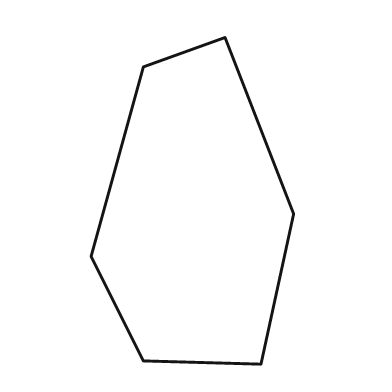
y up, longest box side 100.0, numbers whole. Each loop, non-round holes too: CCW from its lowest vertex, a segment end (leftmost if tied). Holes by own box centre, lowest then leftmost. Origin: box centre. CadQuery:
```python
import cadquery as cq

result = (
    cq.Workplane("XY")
    .moveTo(21.0, -50.0)
    .lineTo(31.0, -4.0)
    .lineTo(10.0, 50.0)
    .lineTo(-15.0, 41.0)
    .lineTo(-31.0, -17.0)
    .lineTo(-15.0, -49.0)
    .close()
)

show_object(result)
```